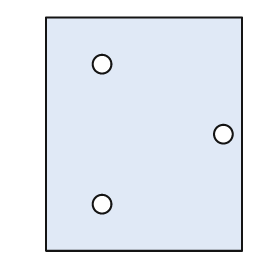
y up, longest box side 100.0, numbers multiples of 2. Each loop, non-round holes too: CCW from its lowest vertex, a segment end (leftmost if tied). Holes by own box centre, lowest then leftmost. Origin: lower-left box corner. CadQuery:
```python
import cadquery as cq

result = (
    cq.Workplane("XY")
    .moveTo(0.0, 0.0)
    .lineTo(84.0, 0.0)
    .lineTo(84.0, 100.0)
    .lineTo(0.0, 100.0)
    .close()
    .moveTo(24.0, 20.0)
    .circle(4.0)
    .moveTo(76.0, 50.0)
    .circle(4.0)
    .moveTo(24.0, 80.0)
    .circle(4.0)
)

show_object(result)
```